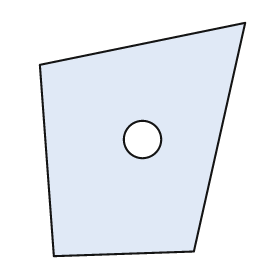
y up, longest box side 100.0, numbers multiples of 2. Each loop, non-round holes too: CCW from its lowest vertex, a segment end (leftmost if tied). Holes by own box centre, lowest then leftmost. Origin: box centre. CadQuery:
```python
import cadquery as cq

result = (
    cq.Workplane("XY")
    .moveTo(-38.0, -50.0)
    .lineTo(22.0, -48.0)
    .lineTo(44.0, 50.0)
    .lineTo(-44.0, 32.0)
    .close()
    .moveTo(0.0, 0.0)
    .circle(8.0)
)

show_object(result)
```